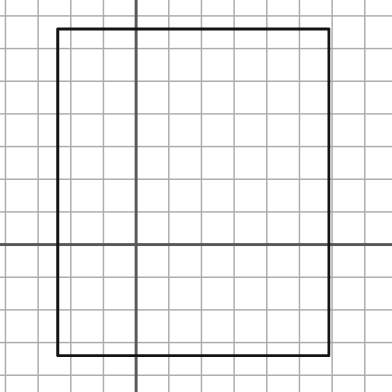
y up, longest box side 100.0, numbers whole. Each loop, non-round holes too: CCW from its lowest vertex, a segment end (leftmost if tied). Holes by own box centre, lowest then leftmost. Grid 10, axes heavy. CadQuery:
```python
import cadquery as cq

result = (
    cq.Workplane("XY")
    .moveTo(-24.0, -34.0)
    .lineTo(59.0, -34.0)
    .lineTo(59.0, 66.0)
    .lineTo(-24.0, 66.0)
    .close()
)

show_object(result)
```